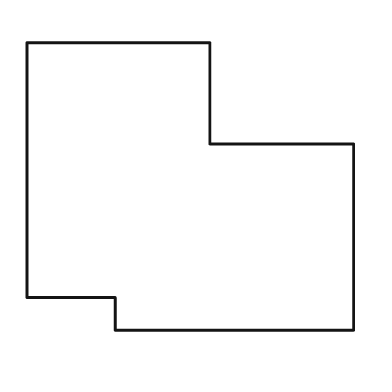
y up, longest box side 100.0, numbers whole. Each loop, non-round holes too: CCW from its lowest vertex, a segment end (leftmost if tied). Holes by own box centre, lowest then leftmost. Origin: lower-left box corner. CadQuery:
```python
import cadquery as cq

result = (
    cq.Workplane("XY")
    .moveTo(27.0, 0.0)
    .lineTo(100.0, 0.0)
    .lineTo(100.0, 57.0)
    .lineTo(56.0, 57.0)
    .lineTo(56.0, 88.0)
    .lineTo(0.0, 88.0)
    .lineTo(0.0, 10.0)
    .lineTo(27.0, 10.0)
    .close()
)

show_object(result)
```